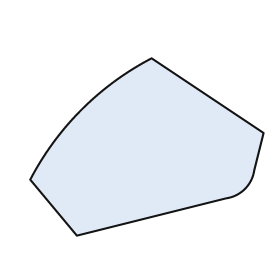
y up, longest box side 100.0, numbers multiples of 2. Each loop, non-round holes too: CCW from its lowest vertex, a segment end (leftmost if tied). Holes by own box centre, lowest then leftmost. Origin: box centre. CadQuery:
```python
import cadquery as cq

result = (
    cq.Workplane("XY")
    .moveTo(-30.0, -38.0)
    .lineTo(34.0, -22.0)
    .threePointArc((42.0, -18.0), (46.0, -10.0))
    .lineTo(50.0, 6.0)
    .lineTo(2.0, 38.0)
    .threePointArc((-28.0, 16.0), (-50.0, -14.0))
    .close()
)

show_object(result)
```